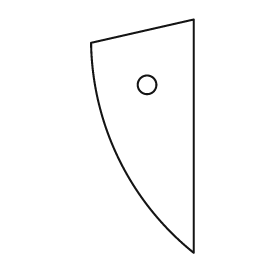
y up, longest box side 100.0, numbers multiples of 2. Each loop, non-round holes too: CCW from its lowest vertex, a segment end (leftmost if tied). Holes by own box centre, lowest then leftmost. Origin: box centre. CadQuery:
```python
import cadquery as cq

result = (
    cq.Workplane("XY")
    .moveTo(22.0, -50.0)
    .lineTo(22.0, 50.0)
    .lineTo(-22.0, 40.0)
    .threePointArc((-10.0, -10.0), (22.0, -50.0))
    .close()
    .moveTo(2.0, 22.0)
    .circle(4.0)
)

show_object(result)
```